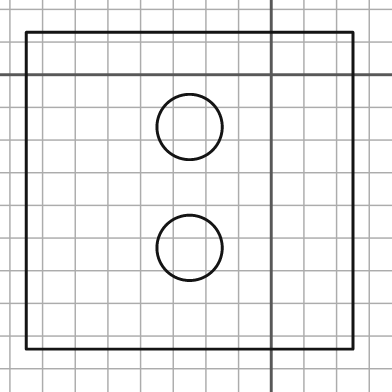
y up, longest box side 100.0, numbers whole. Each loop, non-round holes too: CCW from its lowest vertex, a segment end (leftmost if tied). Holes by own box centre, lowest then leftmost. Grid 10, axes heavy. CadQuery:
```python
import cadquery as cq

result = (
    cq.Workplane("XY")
    .moveTo(-75.0, -84.0)
    .lineTo(25.0, -84.0)
    .lineTo(25.0, 13.0)
    .lineTo(-75.0, 13.0)
    .close()
    .moveTo(-25.0, -53.0)
    .circle(10.0)
    .moveTo(-25.0, -16.0)
    .circle(10.0)
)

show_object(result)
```